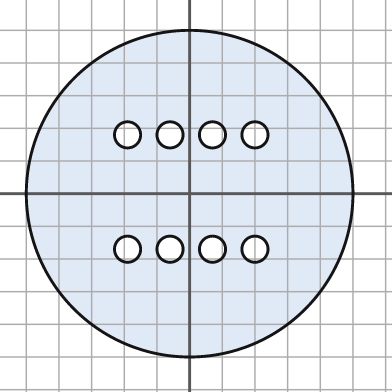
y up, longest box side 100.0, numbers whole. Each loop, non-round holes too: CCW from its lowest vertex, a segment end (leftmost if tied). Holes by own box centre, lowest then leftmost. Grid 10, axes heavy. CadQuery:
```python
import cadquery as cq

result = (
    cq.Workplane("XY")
    .moveTo(0.0, 0.0)
    .circle(50.0)
    .moveTo(-19.0, -17.0)
    .circle(4.0)
    .moveTo(-6.0, -17.0)
    .circle(4.0)
    .moveTo(7.0, -17.0)
    .circle(4.0)
    .moveTo(20.0, -17.0)
    .circle(4.0)
    .moveTo(-19.0, 18.0)
    .circle(4.0)
    .moveTo(-6.0, 18.0)
    .circle(4.0)
    .moveTo(7.0, 18.0)
    .circle(4.0)
    .moveTo(20.0, 18.0)
    .circle(4.0)
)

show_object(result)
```